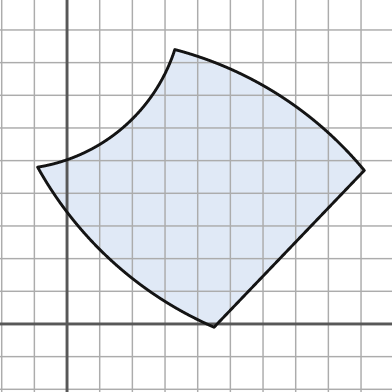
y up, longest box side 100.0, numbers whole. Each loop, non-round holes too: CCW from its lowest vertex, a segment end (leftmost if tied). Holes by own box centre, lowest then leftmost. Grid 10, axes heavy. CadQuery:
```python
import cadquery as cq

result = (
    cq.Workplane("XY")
    .moveTo(45.0, -1.0)
    .lineTo(91.0, 47.0)
    .threePointArc((65.0, 70.0), (33.0, 84.0))
    .threePointArc((17.0, 60.0), (-9.0, 48.0))
    .threePointArc((14.0, 19.0), (45.0, -1.0))
    .close()
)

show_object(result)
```